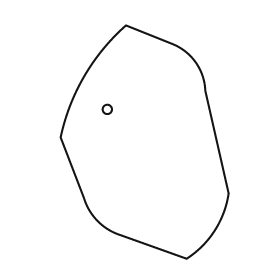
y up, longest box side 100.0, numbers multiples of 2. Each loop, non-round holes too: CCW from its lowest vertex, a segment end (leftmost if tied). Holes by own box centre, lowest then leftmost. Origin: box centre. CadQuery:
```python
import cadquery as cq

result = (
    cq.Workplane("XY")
    .moveTo(18.0, -50.0)
    .threePointArc((30.0, -38.0), (36.0, -22.0))
    .lineTo(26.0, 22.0)
    .threePointArc((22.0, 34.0), (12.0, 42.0))
    .lineTo(-8.0, 50.0)
    .threePointArc((-26.0, 28.0), (-36.0, 2.0))
    .lineTo(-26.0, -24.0)
    .threePointArc((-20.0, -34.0), (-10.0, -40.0))
    .close()
    .moveTo(-16.0, 14.0)
    .circle(2.0)
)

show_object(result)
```